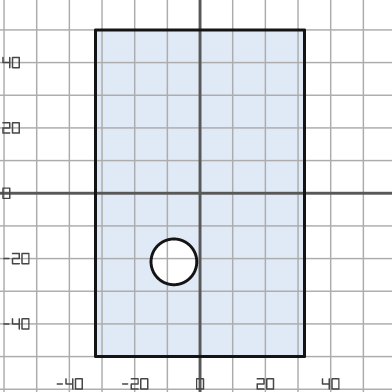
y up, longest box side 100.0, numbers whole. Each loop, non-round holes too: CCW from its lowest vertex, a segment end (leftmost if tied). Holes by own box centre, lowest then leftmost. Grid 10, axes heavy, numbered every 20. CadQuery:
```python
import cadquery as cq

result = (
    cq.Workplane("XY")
    .moveTo(-32.0, -50.0)
    .lineTo(32.0, -50.0)
    .lineTo(32.0, 50.0)
    .lineTo(-32.0, 50.0)
    .close()
    .moveTo(-8.0, -21.0)
    .circle(7.0)
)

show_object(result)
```